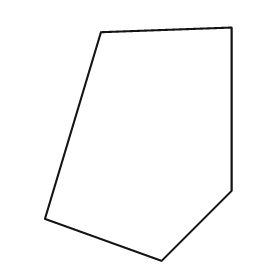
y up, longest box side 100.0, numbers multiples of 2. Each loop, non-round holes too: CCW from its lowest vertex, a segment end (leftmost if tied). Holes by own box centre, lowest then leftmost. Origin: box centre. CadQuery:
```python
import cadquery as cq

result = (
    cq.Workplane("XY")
    .moveTo(10.0, -50.0)
    .lineTo(40.0, -20.0)
    .lineTo(40.0, 50.0)
    .lineTo(-16.0, 48.0)
    .lineTo(-40.0, -32.0)
    .close()
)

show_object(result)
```